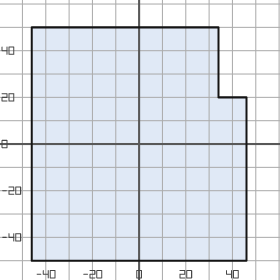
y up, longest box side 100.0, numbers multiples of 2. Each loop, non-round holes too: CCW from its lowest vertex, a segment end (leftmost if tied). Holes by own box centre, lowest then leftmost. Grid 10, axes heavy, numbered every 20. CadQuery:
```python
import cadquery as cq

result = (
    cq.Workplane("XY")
    .moveTo(-46.0, -50.0)
    .lineTo(46.0, -50.0)
    .lineTo(46.0, 20.0)
    .lineTo(34.0, 20.0)
    .lineTo(34.0, 50.0)
    .lineTo(-46.0, 50.0)
    .close()
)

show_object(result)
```